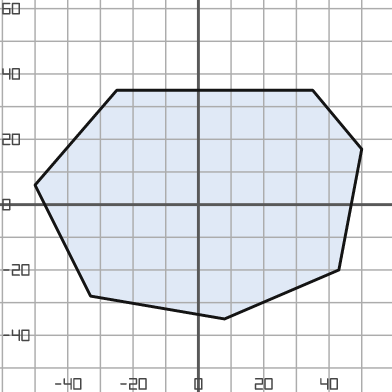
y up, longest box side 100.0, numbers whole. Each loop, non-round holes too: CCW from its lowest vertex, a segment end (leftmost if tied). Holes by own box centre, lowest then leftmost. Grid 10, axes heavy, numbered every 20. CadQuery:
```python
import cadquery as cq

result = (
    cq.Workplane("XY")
    .moveTo(8.0, -35.0)
    .lineTo(43.0, -20.0)
    .lineTo(50.0, 17.0)
    .lineTo(35.0, 35.0)
    .lineTo(-25.0, 35.0)
    .lineTo(-50.0, 6.0)
    .lineTo(-33.0, -28.0)
    .close()
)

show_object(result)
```